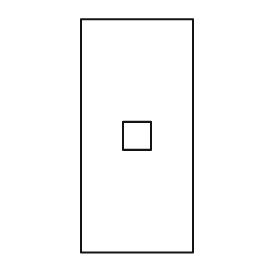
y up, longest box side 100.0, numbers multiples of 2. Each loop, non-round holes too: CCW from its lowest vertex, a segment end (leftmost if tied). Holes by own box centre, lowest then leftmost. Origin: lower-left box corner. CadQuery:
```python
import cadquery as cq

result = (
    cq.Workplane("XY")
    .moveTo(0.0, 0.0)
    .lineTo(48.0, 0.0)
    .lineTo(48.0, 100.0)
    .lineTo(0.0, 100.0)
    .close()
    .moveTo(18.0, 44.0)
    .lineTo(30.0, 44.0)
    .lineTo(30.0, 56.0)
    .lineTo(18.0, 56.0)
    .close()
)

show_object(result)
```